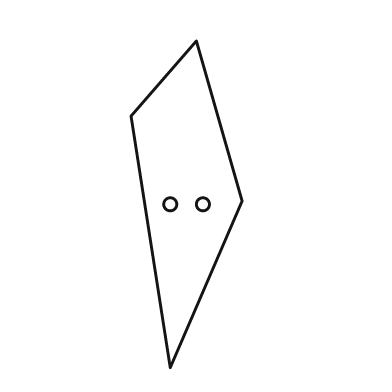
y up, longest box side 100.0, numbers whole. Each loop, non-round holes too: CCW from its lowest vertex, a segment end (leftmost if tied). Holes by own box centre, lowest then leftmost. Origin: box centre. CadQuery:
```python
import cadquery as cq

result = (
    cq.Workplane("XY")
    .moveTo(-5.0, -50.0)
    .lineTo(17.0, 1.0)
    .lineTo(3.0, 50.0)
    .lineTo(-17.0, 27.0)
    .close()
    .moveTo(-5.0, 0.0)
    .circle(2.0)
    .moveTo(5.0, 0.0)
    .circle(2.0)
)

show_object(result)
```